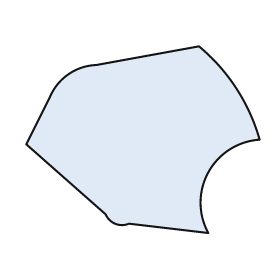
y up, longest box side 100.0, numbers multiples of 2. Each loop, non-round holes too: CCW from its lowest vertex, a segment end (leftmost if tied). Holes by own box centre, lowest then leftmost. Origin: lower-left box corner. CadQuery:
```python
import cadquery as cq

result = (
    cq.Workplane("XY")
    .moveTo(78.0, 0.0)
    .threePointArc((78.0, 26.0), (100.0, 40.0))
    .threePointArc((90.0, 62.0), (74.0, 80.0))
    .lineTo(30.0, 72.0)
    .threePointArc((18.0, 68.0), (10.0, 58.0))
    .lineTo(0.0, 38.0)
    .lineTo(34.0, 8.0)
    .threePointArc((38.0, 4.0), (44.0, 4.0))
    .close()
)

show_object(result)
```